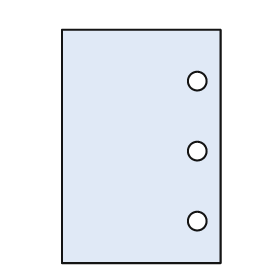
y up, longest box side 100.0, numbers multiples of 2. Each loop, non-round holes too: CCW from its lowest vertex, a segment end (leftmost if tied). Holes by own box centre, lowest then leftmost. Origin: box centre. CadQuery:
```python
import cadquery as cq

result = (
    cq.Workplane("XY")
    .moveTo(-34.0, -50.0)
    .lineTo(34.0, -50.0)
    .lineTo(34.0, 50.0)
    .lineTo(-34.0, 50.0)
    .close()
    .moveTo(24.0, -32.0)
    .circle(4.0)
    .moveTo(24.0, -2.0)
    .circle(4.0)
    .moveTo(24.0, 28.0)
    .circle(4.0)
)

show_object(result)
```